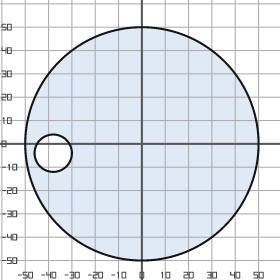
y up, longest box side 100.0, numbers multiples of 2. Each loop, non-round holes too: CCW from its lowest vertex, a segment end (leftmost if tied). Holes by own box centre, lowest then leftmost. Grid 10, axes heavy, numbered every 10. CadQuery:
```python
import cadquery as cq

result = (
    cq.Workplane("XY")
    .moveTo(0.0, 0.0)
    .circle(50.0)
    .moveTo(-38.0, -4.0)
    .circle(8.0)
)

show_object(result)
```